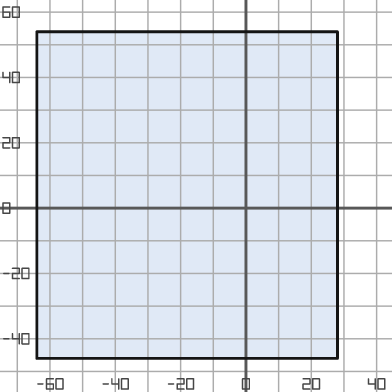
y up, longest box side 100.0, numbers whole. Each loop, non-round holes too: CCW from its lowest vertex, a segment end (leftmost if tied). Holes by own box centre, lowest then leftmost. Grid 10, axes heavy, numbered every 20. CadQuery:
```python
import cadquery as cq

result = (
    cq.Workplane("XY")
    .moveTo(-64.0, -46.0)
    .lineTo(28.0, -46.0)
    .lineTo(28.0, 54.0)
    .lineTo(-64.0, 54.0)
    .close()
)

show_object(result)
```